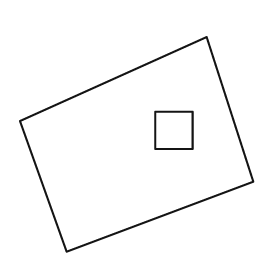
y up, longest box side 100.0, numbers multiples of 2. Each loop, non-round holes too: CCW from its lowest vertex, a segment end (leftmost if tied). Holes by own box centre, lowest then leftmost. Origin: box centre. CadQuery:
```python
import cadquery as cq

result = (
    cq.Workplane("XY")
    .moveTo(-30.0, -46.0)
    .lineTo(50.0, -16.0)
    .lineTo(30.0, 46.0)
    .lineTo(-50.0, 10.0)
    .close()
    .moveTo(8.0, -2.0)
    .lineTo(24.0, -2.0)
    .lineTo(24.0, 14.0)
    .lineTo(8.0, 14.0)
    .close()
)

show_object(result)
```